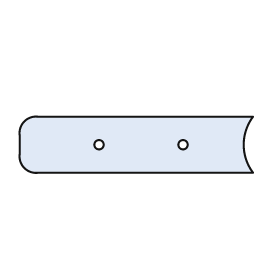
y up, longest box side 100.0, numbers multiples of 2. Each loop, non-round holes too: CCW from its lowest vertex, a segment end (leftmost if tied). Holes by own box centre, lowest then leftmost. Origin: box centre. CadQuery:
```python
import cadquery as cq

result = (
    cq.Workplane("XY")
    .moveTo(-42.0, -12.0)
    .lineTo(50.0, -12.0)
    .threePointArc((46.0, 0.0), (50.0, 12.0))
    .lineTo(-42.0, 12.0)
    .threePointArc((-48.0, 10.0), (-50.0, 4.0))
    .lineTo(-50.0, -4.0)
    .threePointArc((-48.0, -10.0), (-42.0, -12.0))
    .close()
    .moveTo(-16.0, 0.0)
    .circle(2.0)
    .moveTo(20.0, 0.0)
    .circle(2.0)
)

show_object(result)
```